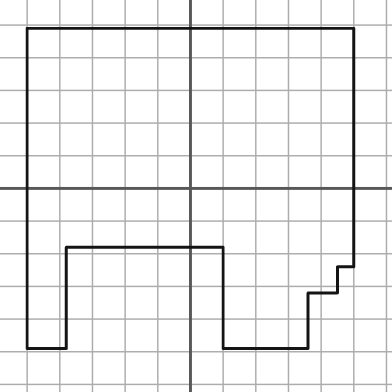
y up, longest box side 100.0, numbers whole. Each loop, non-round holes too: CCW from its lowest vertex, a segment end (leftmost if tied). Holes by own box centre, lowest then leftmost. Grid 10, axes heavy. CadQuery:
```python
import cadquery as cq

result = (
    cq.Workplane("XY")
    .moveTo(-50.0, -49.0)
    .lineTo(-38.0, -49.0)
    .lineTo(-38.0, -18.0)
    .lineTo(10.0, -18.0)
    .lineTo(10.0, -49.0)
    .lineTo(36.0, -49.0)
    .lineTo(36.0, -32.0)
    .lineTo(45.0, -32.0)
    .lineTo(45.0, -24.0)
    .lineTo(50.0, -24.0)
    .lineTo(50.0, 49.0)
    .lineTo(-50.0, 49.0)
    .close()
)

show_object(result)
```